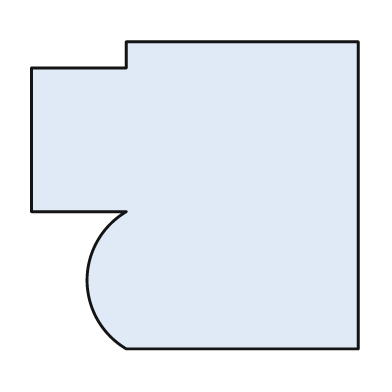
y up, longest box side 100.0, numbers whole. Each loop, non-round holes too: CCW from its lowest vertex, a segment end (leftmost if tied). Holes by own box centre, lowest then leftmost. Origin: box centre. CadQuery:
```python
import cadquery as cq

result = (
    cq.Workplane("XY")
    .moveTo(-21.0, -47.0)
    .lineTo(50.0, -47.0)
    .lineTo(50.0, 47.0)
    .lineTo(-21.0, 47.0)
    .lineTo(-21.0, 39.0)
    .lineTo(-50.0, 39.0)
    .lineTo(-50.0, -5.0)
    .lineTo(-21.0, -5.0)
    .threePointArc((-33.0, -26.0), (-21.0, -47.0))
    .close()
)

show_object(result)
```